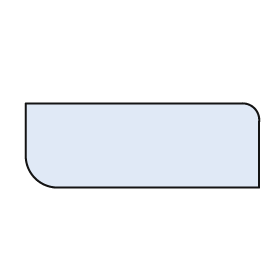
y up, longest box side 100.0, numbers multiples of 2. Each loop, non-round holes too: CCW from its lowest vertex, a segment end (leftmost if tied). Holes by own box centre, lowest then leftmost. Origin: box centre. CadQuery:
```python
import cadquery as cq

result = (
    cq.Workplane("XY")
    .moveTo(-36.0, -18.0)
    .lineTo(50.0, -18.0)
    .lineTo(50.0, 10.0)
    .threePointArc((48.0, 16.0), (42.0, 18.0))
    .lineTo(-50.0, 18.0)
    .lineTo(-50.0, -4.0)
    .threePointArc((-46.0, -14.0), (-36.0, -18.0))
    .close()
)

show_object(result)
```